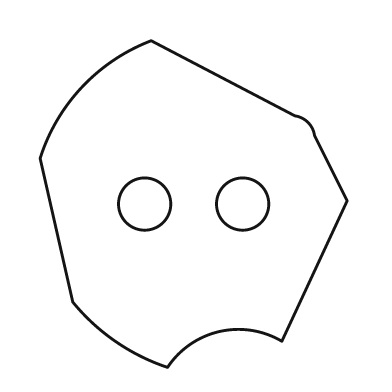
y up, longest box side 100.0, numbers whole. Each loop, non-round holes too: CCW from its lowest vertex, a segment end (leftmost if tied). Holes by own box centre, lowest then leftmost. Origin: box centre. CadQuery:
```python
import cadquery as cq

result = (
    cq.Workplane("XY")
    .moveTo(-8.0, -50.0)
    .threePointArc((8.0, -39.0), (27.0, -42.0))
    .lineTo(47.0, 1.0)
    .lineTo(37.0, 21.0)
    .threePointArc((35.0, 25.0), (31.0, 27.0))
    .lineTo(-13.0, 50.0)
    .threePointArc((-34.0, 36.0), (-47.0, 14.0))
    .lineTo(-37.0, -30.0)
    .threePointArc((-24.0, -42.0), (-8.0, -50.0))
    .close()
    .moveTo(-15.0, 0.0)
    .circle(8.0)
    .moveTo(15.0, 0.0)
    .circle(8.0)
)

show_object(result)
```